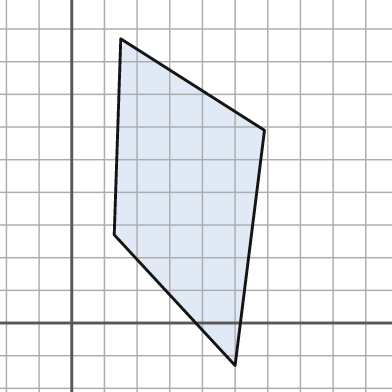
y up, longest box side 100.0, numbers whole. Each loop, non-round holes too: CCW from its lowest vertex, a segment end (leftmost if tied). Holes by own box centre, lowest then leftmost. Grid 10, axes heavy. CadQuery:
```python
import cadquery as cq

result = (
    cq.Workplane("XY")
    .moveTo(50.0, -13.0)
    .lineTo(59.0, 59.0)
    .lineTo(15.0, 87.0)
    .lineTo(13.0, 27.0)
    .close()
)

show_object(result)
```